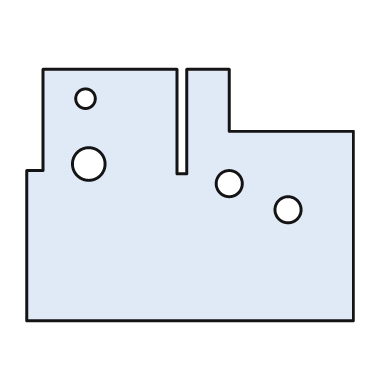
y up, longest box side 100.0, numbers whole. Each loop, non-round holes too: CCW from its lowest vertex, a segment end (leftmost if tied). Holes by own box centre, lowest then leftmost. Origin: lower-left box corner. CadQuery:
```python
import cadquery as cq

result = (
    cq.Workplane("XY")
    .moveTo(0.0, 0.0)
    .lineTo(100.0, 0.0)
    .lineTo(100.0, 58.0)
    .lineTo(62.0, 58.0)
    .lineTo(62.0, 77.0)
    .lineTo(49.0, 77.0)
    .lineTo(49.0, 45.0)
    .lineTo(46.0, 45.0)
    .lineTo(46.0, 77.0)
    .lineTo(5.0, 77.0)
    .lineTo(5.0, 46.0)
    .lineTo(0.0, 46.0)
    .close()
    .moveTo(80.0, 34.0)
    .circle(4.0)
    .moveTo(62.0, 42.0)
    .circle(4.0)
    .moveTo(19.0, 48.0)
    .circle(5.0)
    .moveTo(18.0, 68.0)
    .circle(3.0)
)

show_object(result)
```